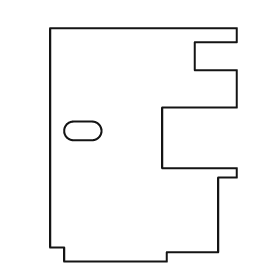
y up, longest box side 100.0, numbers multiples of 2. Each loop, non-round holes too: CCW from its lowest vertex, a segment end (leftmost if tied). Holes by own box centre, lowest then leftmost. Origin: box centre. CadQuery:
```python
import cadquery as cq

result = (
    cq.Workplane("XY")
    .moveTo(-34.0, -50.0)
    .lineTo(10.0, -50.0)
    .lineTo(10.0, -46.0)
    .lineTo(32.0, -46.0)
    .lineTo(32.0, -14.0)
    .lineTo(40.0, -14.0)
    .lineTo(40.0, -10.0)
    .lineTo(8.0, -10.0)
    .lineTo(8.0, 16.0)
    .lineTo(40.0, 16.0)
    .lineTo(40.0, 32.0)
    .lineTo(22.0, 32.0)
    .lineTo(22.0, 44.0)
    .lineTo(40.0, 44.0)
    .lineTo(40.0, 50.0)
    .lineTo(-40.0, 50.0)
    .lineTo(-40.0, -44.0)
    .lineTo(-34.0, -44.0)
    .close()
    .moveTo(-30.0, 2.0)
    .lineTo(-22.0, 2.0)
    .threePointArc((-18.0, 6.0), (-22.0, 10.0))
    .lineTo(-30.0, 10.0)
    .threePointArc((-34.0, 6.0), (-30.0, 2.0))
    .close()
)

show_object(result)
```